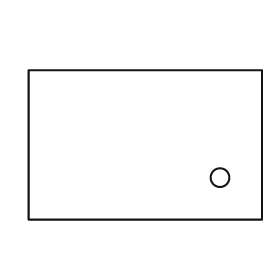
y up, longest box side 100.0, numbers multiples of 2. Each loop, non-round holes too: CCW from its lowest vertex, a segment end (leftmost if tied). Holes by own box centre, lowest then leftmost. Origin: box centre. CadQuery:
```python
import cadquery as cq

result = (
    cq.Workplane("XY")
    .moveTo(-50.0, -32.0)
    .lineTo(50.0, -32.0)
    .lineTo(50.0, 32.0)
    .lineTo(-50.0, 32.0)
    .close()
    .moveTo(32.0, -14.0)
    .circle(4.0)
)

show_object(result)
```